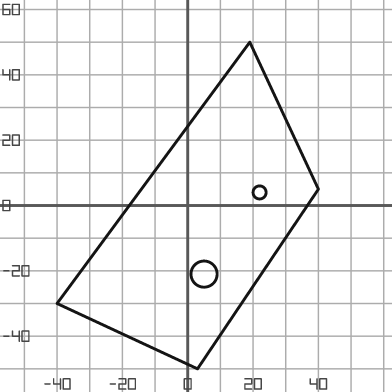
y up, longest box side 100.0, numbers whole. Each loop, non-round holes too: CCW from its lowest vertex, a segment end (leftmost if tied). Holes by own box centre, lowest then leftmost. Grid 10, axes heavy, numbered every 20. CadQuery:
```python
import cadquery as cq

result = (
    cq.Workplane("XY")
    .moveTo(3.0, -50.0)
    .lineTo(40.0, 5.0)
    .lineTo(19.0, 50.0)
    .lineTo(-40.0, -30.0)
    .close()
    .moveTo(5.0, -21.0)
    .circle(4.0)
    .moveTo(22.0, 4.0)
    .circle(2.0)
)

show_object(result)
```